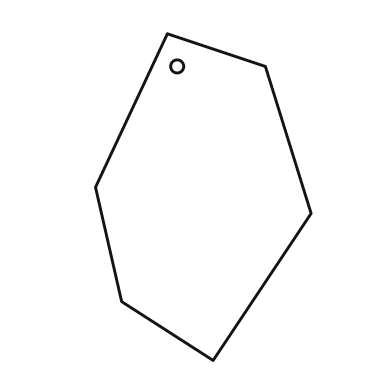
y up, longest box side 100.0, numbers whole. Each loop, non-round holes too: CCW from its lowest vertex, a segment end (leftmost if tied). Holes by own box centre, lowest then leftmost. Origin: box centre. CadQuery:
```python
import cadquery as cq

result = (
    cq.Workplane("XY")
    .moveTo(3.0, -50.0)
    .lineTo(33.0, -5.0)
    .lineTo(19.0, 40.0)
    .lineTo(-11.0, 50.0)
    .lineTo(-33.0, 3.0)
    .lineTo(-25.0, -32.0)
    .close()
    .moveTo(-8.0, 40.0)
    .circle(2.0)
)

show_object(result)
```